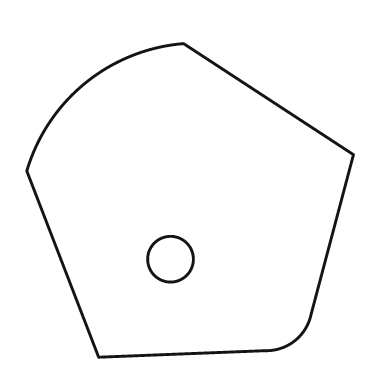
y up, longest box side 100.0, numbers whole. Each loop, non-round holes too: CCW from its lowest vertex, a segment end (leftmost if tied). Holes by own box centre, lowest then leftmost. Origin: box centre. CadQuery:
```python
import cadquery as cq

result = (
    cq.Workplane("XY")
    .moveTo(-28.0, -48.0)
    .lineTo(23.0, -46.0)
    .threePointArc((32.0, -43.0), (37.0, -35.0))
    .lineTo(50.0, 14.0)
    .lineTo(-2.0, 48.0)
    .threePointArc((-32.0, 36.0), (-50.0, 9.0))
    .close()
    .moveTo(-6.0, -18.0)
    .circle(7.0)
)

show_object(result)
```